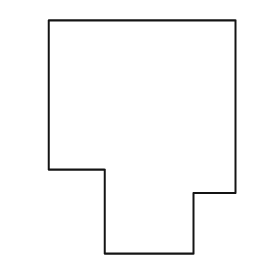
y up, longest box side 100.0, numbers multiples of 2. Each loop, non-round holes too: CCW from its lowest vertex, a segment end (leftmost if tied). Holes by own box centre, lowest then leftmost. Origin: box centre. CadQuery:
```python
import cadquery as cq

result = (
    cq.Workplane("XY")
    .moveTo(-16.0, -50.0)
    .lineTo(22.0, -50.0)
    .lineTo(22.0, -24.0)
    .lineTo(40.0, -24.0)
    .lineTo(40.0, 50.0)
    .lineTo(-40.0, 50.0)
    .lineTo(-40.0, -14.0)
    .lineTo(-16.0, -14.0)
    .close()
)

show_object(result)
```